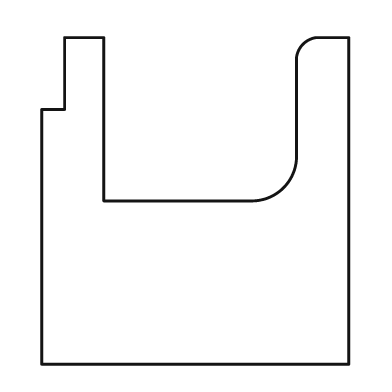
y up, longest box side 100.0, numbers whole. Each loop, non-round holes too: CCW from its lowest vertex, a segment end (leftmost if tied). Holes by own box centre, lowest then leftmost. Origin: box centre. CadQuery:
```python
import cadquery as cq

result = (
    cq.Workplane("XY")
    .moveTo(-47.0, -50.0)
    .lineTo(47.0, -50.0)
    .lineTo(47.0, 50.0)
    .lineTo(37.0, 50.0)
    .threePointArc((33.0, 48.0), (31.0, 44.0))
    .lineTo(31.0, 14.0)
    .threePointArc((27.0, 4.0), (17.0, 0.0))
    .lineTo(-28.0, 0.0)
    .lineTo(-28.0, 50.0)
    .lineTo(-40.0, 50.0)
    .lineTo(-40.0, 28.0)
    .lineTo(-47.0, 28.0)
    .close()
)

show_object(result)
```